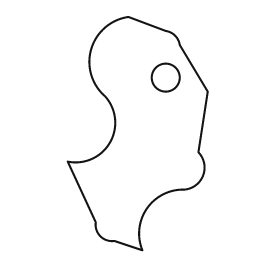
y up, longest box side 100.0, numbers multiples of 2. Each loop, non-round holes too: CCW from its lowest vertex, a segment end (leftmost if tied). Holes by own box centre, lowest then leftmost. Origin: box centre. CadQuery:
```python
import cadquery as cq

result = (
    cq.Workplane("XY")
    .moveTo(2.0, -50.0)
    .threePointArc((4.0, -32.0), (20.0, -24.0))
    .threePointArc((28.0, -18.0), (26.0, -8.0))
    .lineTo(30.0, 18.0)
    .lineTo(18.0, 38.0)
    .threePointArc((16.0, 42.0), (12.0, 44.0))
    .lineTo(-4.0, 50.0)
    .threePointArc((-20.0, 36.0), (-14.0, 16.0))
    .threePointArc((-12.0, -4.0), (-30.0, -12.0))
    .lineTo(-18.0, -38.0)
    .threePointArc((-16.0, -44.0), (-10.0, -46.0))
    .close()
    .moveTo(12.0, 24.0)
    .circle(6.0)
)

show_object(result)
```